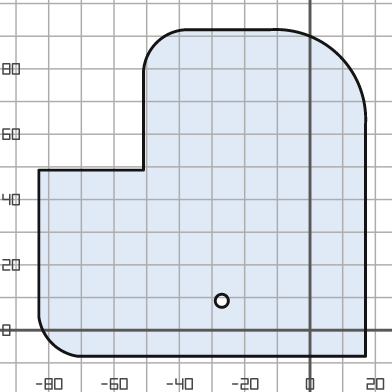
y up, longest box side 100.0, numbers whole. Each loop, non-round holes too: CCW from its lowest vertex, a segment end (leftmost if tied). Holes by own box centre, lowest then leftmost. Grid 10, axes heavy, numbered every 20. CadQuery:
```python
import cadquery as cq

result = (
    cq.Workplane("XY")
    .moveTo(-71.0, -8.0)
    .lineTo(17.0, -8.0)
    .lineTo(17.0, 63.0)
    .threePointArc((9.0, 84.0), (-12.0, 92.0))
    .lineTo(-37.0, 92.0)
    .threePointArc((-47.0, 88.0), (-51.0, 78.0))
    .lineTo(-51.0, 49.0)
    .lineTo(-83.0, 49.0)
    .lineTo(-83.0, 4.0)
    .threePointArc((-79.0, -4.0), (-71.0, -8.0))
    .close()
    .moveTo(-27.0, 9.0)
    .circle(2.0)
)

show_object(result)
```